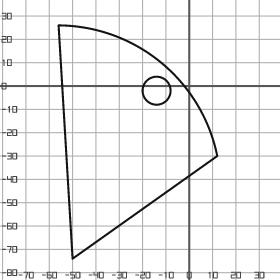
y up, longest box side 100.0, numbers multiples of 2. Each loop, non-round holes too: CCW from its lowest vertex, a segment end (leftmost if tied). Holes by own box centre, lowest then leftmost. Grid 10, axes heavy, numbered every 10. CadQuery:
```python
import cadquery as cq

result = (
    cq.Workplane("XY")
    .moveTo(-50.0, -74.0)
    .lineTo(12.0, -30.0)
    .threePointArc((-12.0, 10.0), (-56.0, 26.0))
    .close()
    .moveTo(-14.0, -2.0)
    .circle(6.0)
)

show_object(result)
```